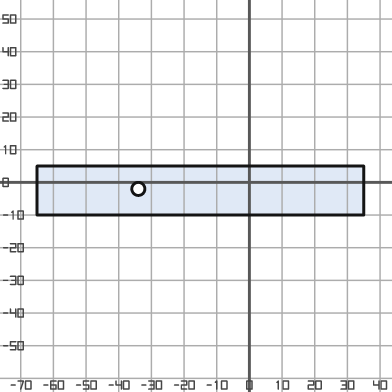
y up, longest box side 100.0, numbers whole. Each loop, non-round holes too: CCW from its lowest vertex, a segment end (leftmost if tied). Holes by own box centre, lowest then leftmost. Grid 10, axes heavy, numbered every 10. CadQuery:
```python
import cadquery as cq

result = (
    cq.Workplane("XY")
    .moveTo(-65.0, -10.0)
    .lineTo(35.0, -10.0)
    .lineTo(35.0, 5.0)
    .lineTo(-65.0, 5.0)
    .close()
    .moveTo(-34.0, -2.0)
    .circle(2.0)
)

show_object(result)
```